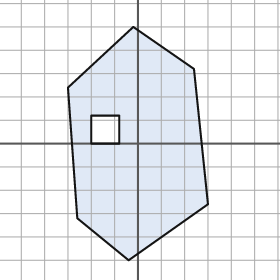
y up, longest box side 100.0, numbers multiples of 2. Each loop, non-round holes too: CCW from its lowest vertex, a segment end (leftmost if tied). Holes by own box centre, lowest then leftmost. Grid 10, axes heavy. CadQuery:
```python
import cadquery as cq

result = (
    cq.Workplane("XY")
    .moveTo(-4.0, -50.0)
    .lineTo(30.0, -26.0)
    .lineTo(24.0, 32.0)
    .lineTo(-2.0, 50.0)
    .lineTo(-30.0, 24.0)
    .lineTo(-26.0, -32.0)
    .close()
    .moveTo(-20.0, 0.0)
    .lineTo(-8.0, 0.0)
    .lineTo(-8.0, 12.0)
    .lineTo(-20.0, 12.0)
    .close()
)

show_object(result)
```